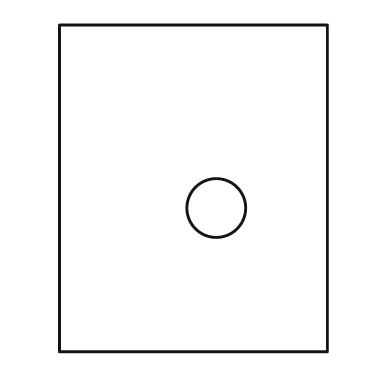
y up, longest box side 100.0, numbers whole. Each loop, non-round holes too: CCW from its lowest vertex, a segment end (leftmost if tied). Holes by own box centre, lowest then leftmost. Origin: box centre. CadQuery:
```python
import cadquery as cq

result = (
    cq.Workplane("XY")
    .moveTo(-41.0, -50.0)
    .lineTo(41.0, -50.0)
    .lineTo(41.0, 50.0)
    .lineTo(-41.0, 50.0)
    .close()
    .moveTo(7.0, -6.0)
    .circle(9.0)
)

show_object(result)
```